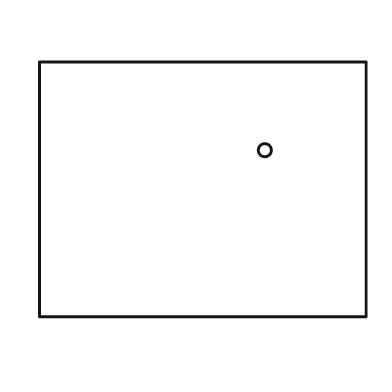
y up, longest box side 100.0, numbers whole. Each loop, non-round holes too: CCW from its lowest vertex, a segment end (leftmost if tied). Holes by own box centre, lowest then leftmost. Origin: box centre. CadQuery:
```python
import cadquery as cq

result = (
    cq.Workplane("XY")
    .moveTo(-50.0, -39.0)
    .lineTo(50.0, -39.0)
    .lineTo(50.0, 39.0)
    .lineTo(-50.0, 39.0)
    .close()
    .moveTo(19.0, 12.0)
    .circle(2.0)
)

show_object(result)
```